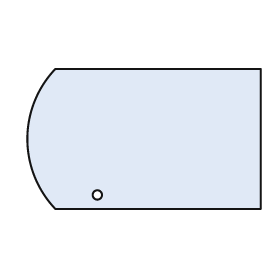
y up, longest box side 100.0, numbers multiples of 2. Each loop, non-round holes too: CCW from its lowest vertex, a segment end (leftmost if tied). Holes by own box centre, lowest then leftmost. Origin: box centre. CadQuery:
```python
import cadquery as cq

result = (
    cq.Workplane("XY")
    .moveTo(-38.0, -30.0)
    .lineTo(50.0, -30.0)
    .lineTo(50.0, 30.0)
    .lineTo(-38.0, 30.0)
    .threePointArc((-50.0, 0.0), (-38.0, -30.0))
    .close()
    .moveTo(-20.0, -24.0)
    .circle(2.0)
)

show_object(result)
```